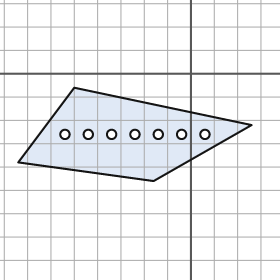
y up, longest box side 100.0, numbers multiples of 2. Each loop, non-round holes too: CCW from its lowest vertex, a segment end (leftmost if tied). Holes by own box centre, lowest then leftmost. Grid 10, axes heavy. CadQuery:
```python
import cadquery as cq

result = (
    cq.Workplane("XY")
    .moveTo(-16.0, -46.0)
    .lineTo(26.0, -22.0)
    .lineTo(-50.0, -6.0)
    .lineTo(-74.0, -38.0)
    .close()
    .moveTo(-54.0, -26.0)
    .circle(2.0)
    .moveTo(-44.0, -26.0)
    .circle(2.0)
    .moveTo(-34.0, -26.0)
    .circle(2.0)
    .moveTo(-24.0, -26.0)
    .circle(2.0)
    .moveTo(-14.0, -26.0)
    .circle(2.0)
    .moveTo(-4.0, -26.0)
    .circle(2.0)
    .moveTo(6.0, -26.0)
    .circle(2.0)
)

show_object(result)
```